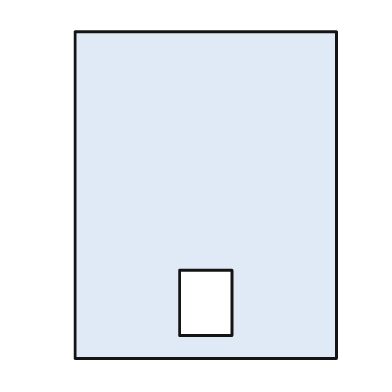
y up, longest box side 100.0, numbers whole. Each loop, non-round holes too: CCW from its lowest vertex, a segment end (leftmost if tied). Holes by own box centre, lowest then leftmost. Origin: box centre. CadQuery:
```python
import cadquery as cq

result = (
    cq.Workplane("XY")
    .moveTo(-40.0, -50.0)
    .lineTo(40.0, -50.0)
    .lineTo(40.0, 50.0)
    .lineTo(-40.0, 50.0)
    .close()
    .moveTo(-8.0, -43.0)
    .lineTo(8.0, -43.0)
    .lineTo(8.0, -23.0)
    .lineTo(-8.0, -23.0)
    .close()
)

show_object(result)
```